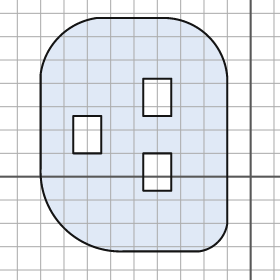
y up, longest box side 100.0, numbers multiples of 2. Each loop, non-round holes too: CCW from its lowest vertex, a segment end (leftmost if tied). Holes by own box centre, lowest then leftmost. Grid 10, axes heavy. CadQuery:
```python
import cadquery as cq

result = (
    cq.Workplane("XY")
    .moveTo(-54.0, -32.0)
    .lineTo(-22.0, -32.0)
    .threePointArc((-14.0, -28.0), (-10.0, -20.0))
    .lineTo(-10.0, 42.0)
    .threePointArc((-18.0, 60.0), (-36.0, 68.0))
    .lineTo(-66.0, 68.0)
    .threePointArc((-82.0, 60.0), (-90.0, 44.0))
    .lineTo(-90.0, 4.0)
    .threePointArc((-80.0, -22.0), (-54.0, -32.0))
    .close()
    .moveTo(-46.0, -6.0)
    .lineTo(-34.0, -6.0)
    .lineTo(-34.0, 10.0)
    .lineTo(-46.0, 10.0)
    .close()
    .moveTo(-76.0, 10.0)
    .lineTo(-64.0, 10.0)
    .lineTo(-64.0, 26.0)
    .lineTo(-76.0, 26.0)
    .close()
    .moveTo(-46.0, 26.0)
    .lineTo(-34.0, 26.0)
    .lineTo(-34.0, 42.0)
    .lineTo(-46.0, 42.0)
    .close()
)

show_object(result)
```